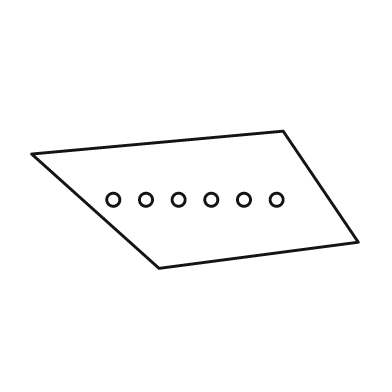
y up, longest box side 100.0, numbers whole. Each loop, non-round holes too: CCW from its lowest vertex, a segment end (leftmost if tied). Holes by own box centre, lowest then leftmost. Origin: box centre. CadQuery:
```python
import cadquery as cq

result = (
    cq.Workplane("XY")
    .moveTo(-11.0, -21.0)
    .lineTo(50.0, -13.0)
    .lineTo(27.0, 21.0)
    .lineTo(-50.0, 14.0)
    .close()
    .moveTo(-25.0, 0.0)
    .circle(2.0)
    .moveTo(-15.0, 0.0)
    .circle(2.0)
    .moveTo(-5.0, 0.0)
    .circle(2.0)
    .moveTo(5.0, 0.0)
    .circle(2.0)
    .moveTo(15.0, 0.0)
    .circle(2.0)
    .moveTo(25.0, 0.0)
    .circle(2.0)
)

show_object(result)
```